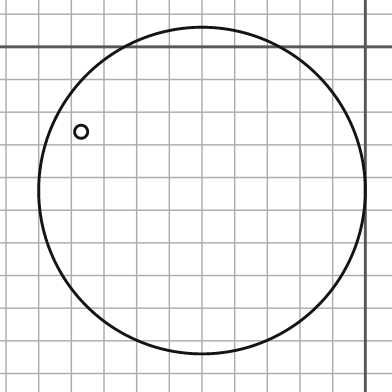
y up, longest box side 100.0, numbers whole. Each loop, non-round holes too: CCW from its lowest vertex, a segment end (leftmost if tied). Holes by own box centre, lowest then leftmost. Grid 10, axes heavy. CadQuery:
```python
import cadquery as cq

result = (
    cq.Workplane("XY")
    .moveTo(-50.0, -44.0)
    .circle(50.0)
    .moveTo(-87.0, -26.0)
    .circle(2.0)
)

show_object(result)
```